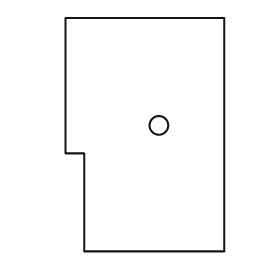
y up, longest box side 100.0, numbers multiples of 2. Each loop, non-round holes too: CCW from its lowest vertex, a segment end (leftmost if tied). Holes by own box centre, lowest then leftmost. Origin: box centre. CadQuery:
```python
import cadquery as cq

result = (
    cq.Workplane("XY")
    .moveTo(-26.0, -50.0)
    .lineTo(34.0, -50.0)
    .lineTo(34.0, 50.0)
    .lineTo(-34.0, 50.0)
    .lineTo(-34.0, -8.0)
    .lineTo(-26.0, -8.0)
    .close()
    .moveTo(6.0, 4.0)
    .circle(4.0)
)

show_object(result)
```